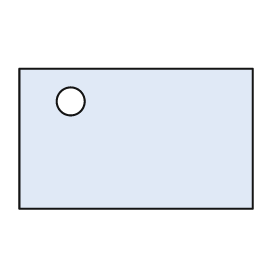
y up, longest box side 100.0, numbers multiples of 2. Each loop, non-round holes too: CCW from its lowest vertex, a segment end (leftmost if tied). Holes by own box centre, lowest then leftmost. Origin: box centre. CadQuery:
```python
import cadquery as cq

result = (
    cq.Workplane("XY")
    .moveTo(-50.0, -30.0)
    .lineTo(50.0, -30.0)
    .lineTo(50.0, 30.0)
    .lineTo(-50.0, 30.0)
    .close()
    .moveTo(-28.0, 16.0)
    .circle(6.0)
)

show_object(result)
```